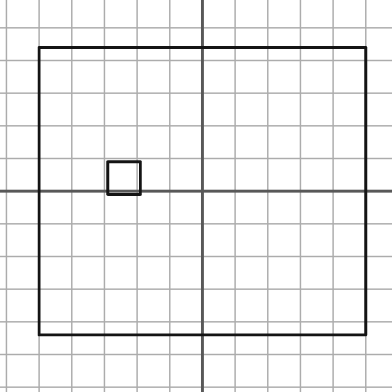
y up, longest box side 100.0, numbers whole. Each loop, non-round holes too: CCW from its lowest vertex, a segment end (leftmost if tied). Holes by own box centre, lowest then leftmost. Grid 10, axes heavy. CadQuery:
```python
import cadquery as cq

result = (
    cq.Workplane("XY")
    .moveTo(-50.0, -44.0)
    .lineTo(50.0, -44.0)
    .lineTo(50.0, 44.0)
    .lineTo(-50.0, 44.0)
    .close()
    .moveTo(-29.0, -1.0)
    .lineTo(-19.0, -1.0)
    .lineTo(-19.0, 9.0)
    .lineTo(-29.0, 9.0)
    .close()
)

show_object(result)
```